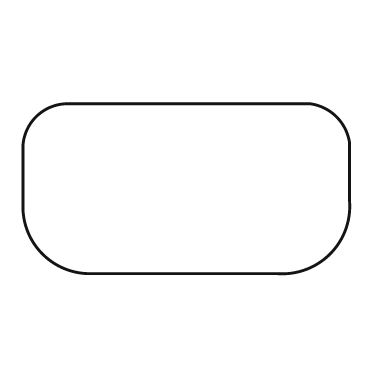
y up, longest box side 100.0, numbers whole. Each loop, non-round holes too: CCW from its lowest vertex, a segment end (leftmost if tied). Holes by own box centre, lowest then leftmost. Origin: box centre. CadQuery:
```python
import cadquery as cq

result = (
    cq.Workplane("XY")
    .moveTo(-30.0, -26.0)
    .lineTo(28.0, -26.0)
    .threePointArc((44.0, -20.0), (50.0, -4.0))
    .lineTo(50.0, 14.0)
    .threePointArc((46.0, 22.0), (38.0, 26.0))
    .lineTo(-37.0, 26.0)
    .threePointArc((-46.0, 22.0), (-50.0, 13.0))
    .lineTo(-50.0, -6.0)
    .threePointArc((-44.0, -20.0), (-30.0, -26.0))
    .close()
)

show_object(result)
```